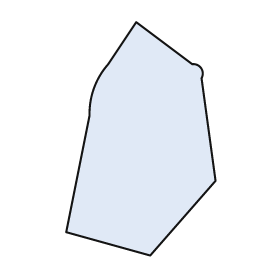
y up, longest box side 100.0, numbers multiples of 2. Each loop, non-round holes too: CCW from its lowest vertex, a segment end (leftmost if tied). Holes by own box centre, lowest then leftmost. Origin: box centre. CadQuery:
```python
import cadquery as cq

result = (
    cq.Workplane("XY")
    .moveTo(4.0, -50.0)
    .lineTo(32.0, -18.0)
    .lineTo(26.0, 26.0)
    .threePointArc((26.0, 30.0), (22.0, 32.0))
    .lineTo(-2.0, 50.0)
    .lineTo(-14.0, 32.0)
    .threePointArc((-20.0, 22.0), (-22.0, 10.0))
    .lineTo(-32.0, -40.0)
    .close()
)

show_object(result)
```